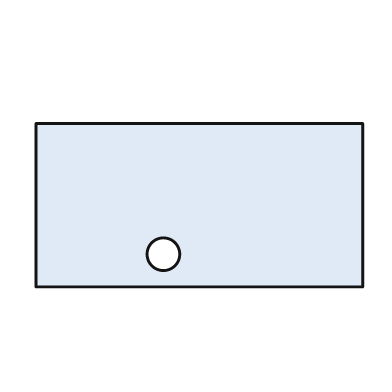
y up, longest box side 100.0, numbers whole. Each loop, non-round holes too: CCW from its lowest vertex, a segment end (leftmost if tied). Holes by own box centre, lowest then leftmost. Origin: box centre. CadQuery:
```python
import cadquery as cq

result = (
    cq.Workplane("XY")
    .moveTo(-50.0, -25.0)
    .lineTo(50.0, -25.0)
    .lineTo(50.0, 25.0)
    .lineTo(-50.0, 25.0)
    .close()
    .moveTo(-11.0, -15.0)
    .circle(5.0)
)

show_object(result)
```